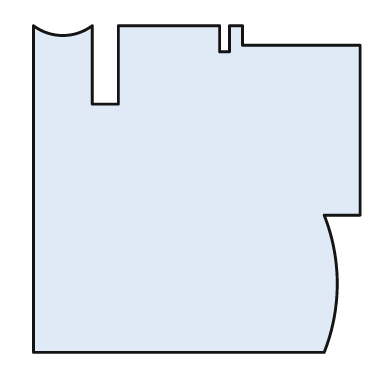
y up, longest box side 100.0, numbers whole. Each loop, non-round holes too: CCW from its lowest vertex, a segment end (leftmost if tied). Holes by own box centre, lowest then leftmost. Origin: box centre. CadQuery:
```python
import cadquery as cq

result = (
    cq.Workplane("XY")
    .moveTo(-50.0, -50.0)
    .lineTo(39.0, -50.0)
    .threePointArc((43.0, -29.0), (39.0, -8.0))
    .lineTo(50.0, -8.0)
    .lineTo(50.0, 44.0)
    .lineTo(14.0, 44.0)
    .lineTo(14.0, 50.0)
    .lineTo(10.0, 50.0)
    .lineTo(10.0, 42.0)
    .lineTo(7.0, 42.0)
    .lineTo(7.0, 50.0)
    .lineTo(-24.0, 50.0)
    .lineTo(-24.0, 26.0)
    .lineTo(-32.0, 26.0)
    .lineTo(-32.0, 50.0)
    .threePointArc((-41.0, 47.0), (-50.0, 50.0))
    .close()
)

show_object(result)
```